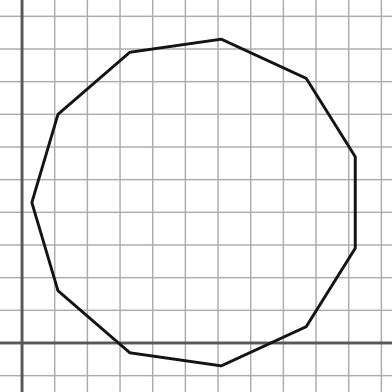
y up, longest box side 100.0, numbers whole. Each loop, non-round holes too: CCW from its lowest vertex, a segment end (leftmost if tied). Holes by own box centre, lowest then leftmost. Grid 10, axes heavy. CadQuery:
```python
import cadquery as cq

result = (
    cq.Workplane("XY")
    .moveTo(61.0, -7.0)
    .lineTo(87.0, 5.0)
    .lineTo(102.0, 29.0)
    .lineTo(102.0, 57.0)
    .lineTo(87.0, 81.0)
    .lineTo(61.0, 93.0)
    .lineTo(33.0, 89.0)
    .lineTo(11.0, 70.0)
    .lineTo(3.0, 43.0)
    .lineTo(11.0, 16.0)
    .lineTo(33.0, -3.0)
    .close()
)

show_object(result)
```